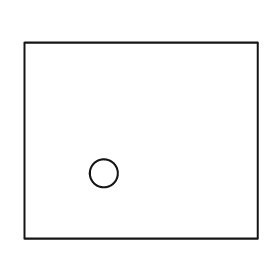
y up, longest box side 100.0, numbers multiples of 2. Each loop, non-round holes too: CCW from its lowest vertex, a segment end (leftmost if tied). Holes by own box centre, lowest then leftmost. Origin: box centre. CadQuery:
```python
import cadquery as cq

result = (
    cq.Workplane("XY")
    .moveTo(-50.0, -42.0)
    .lineTo(50.0, -42.0)
    .lineTo(50.0, 42.0)
    .lineTo(-50.0, 42.0)
    .close()
    .moveTo(-16.0, -14.0)
    .circle(6.0)
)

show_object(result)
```